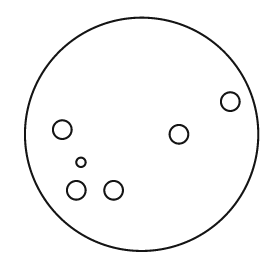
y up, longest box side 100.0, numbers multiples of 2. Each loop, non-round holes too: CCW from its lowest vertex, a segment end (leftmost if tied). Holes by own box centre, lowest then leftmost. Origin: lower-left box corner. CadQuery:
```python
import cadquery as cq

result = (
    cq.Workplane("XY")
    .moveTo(50.0, 50.0)
    .circle(50.0)
    .moveTo(22.0, 26.0)
    .circle(4.0)
    .moveTo(38.0, 26.0)
    .circle(4.0)
    .moveTo(24.0, 38.0)
    .circle(2.0)
    .moveTo(66.0, 50.0)
    .circle(4.0)
    .moveTo(16.0, 52.0)
    .circle(4.0)
    .moveTo(88.0, 64.0)
    .circle(4.0)
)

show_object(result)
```